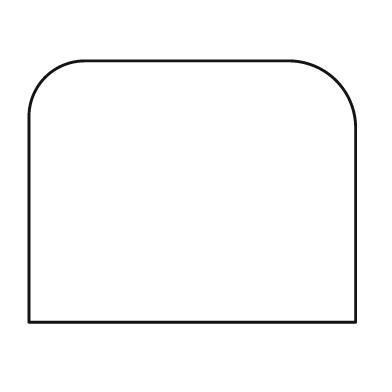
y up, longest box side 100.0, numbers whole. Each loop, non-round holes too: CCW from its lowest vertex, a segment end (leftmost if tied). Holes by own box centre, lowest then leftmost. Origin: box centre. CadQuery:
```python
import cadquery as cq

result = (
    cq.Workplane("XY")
    .moveTo(-50.0, -40.0)
    .lineTo(50.0, -40.0)
    .lineTo(50.0, 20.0)
    .threePointArc((44.0, 34.0), (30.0, 40.0))
    .lineTo(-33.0, 40.0)
    .threePointArc((-45.0, 35.0), (-50.0, 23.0))
    .close()
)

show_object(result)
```